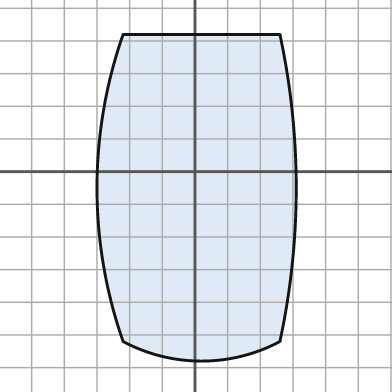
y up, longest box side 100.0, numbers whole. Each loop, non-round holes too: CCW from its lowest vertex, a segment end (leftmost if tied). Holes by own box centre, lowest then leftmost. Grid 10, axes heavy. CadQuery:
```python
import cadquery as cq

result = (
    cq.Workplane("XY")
    .moveTo(-22.0, -52.0)
    .threePointArc((2.0, -58.0), (26.0, -52.0))
    .threePointArc((31.0, -5.0), (26.0, 42.0))
    .lineTo(-22.0, 42.0)
    .threePointArc((-30.0, -5.0), (-22.0, -52.0))
    .close()
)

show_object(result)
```